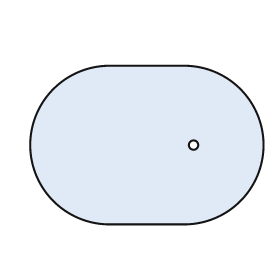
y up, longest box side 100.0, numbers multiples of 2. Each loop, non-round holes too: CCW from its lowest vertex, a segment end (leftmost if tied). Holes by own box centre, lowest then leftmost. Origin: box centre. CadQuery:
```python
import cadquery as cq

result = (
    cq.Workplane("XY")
    .moveTo(-16.0, -34.0)
    .lineTo(16.0, -34.0)
    .threePointArc((50.0, 0.0), (16.0, 34.0))
    .lineTo(-16.0, 34.0)
    .threePointArc((-50.0, 0.0), (-16.0, -34.0))
    .close()
    .moveTo(20.0, 0.0)
    .circle(2.0)
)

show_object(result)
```